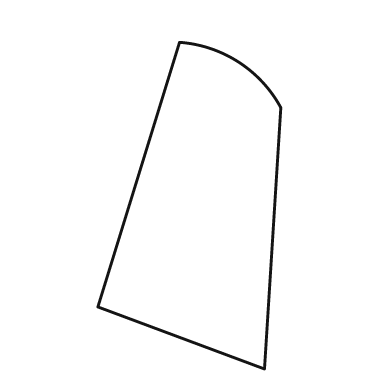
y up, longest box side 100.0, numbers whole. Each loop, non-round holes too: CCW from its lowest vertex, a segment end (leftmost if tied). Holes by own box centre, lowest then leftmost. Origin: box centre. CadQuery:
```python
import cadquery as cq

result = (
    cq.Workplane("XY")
    .moveTo(23.0, -50.0)
    .lineTo(28.0, 30.0)
    .threePointArc((15.0, 44.0), (-3.0, 50.0))
    .lineTo(-28.0, -31.0)
    .close()
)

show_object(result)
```